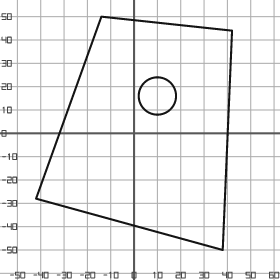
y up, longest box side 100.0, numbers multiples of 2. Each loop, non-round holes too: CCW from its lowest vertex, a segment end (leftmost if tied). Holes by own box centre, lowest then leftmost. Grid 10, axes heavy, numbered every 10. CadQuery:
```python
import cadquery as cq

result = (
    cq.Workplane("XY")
    .moveTo(38.0, -50.0)
    .lineTo(42.0, 44.0)
    .lineTo(-14.0, 50.0)
    .lineTo(-42.0, -28.0)
    .close()
    .moveTo(10.0, 16.0)
    .circle(8.0)
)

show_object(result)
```